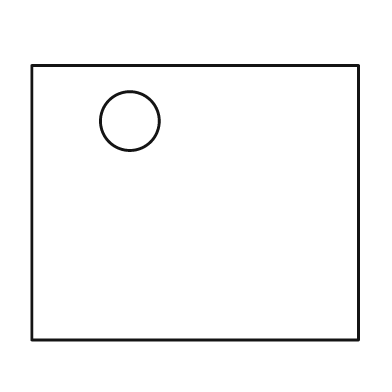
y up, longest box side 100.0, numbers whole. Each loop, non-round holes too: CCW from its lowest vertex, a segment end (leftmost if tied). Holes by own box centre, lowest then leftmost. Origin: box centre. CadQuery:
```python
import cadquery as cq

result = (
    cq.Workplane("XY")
    .moveTo(-50.0, -42.0)
    .lineTo(50.0, -42.0)
    .lineTo(50.0, 42.0)
    .lineTo(-50.0, 42.0)
    .close()
    .moveTo(-20.0, 25.0)
    .circle(9.0)
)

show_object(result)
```